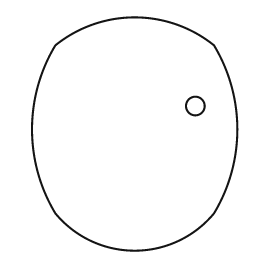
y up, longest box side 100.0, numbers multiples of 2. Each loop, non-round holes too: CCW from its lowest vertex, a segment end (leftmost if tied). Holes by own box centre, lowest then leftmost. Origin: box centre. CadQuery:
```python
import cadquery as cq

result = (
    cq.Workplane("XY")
    .moveTo(-34.0, -34.0)
    .threePointArc((0.0, -50.0), (34.0, -34.0))
    .threePointArc((44.0, 2.0), (34.0, 38.0))
    .threePointArc((0.0, 50.0), (-34.0, 38.0))
    .threePointArc((-44.0, 2.0), (-34.0, -34.0))
    .close()
    .moveTo(26.0, 12.0)
    .circle(4.0)
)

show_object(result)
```